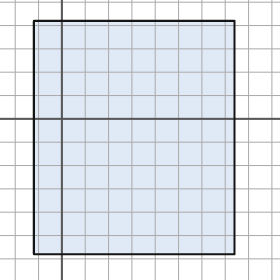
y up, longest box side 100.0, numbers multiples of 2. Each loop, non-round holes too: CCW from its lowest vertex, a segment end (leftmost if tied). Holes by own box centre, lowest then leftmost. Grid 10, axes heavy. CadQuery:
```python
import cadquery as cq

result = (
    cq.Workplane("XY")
    .moveTo(-12.0, -58.0)
    .lineTo(74.0, -58.0)
    .lineTo(74.0, 42.0)
    .lineTo(-12.0, 42.0)
    .close()
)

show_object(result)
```